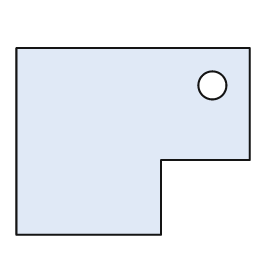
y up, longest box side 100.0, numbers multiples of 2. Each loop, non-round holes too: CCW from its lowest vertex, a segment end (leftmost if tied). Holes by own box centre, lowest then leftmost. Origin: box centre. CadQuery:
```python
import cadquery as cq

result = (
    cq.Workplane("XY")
    .moveTo(-50.0, -40.0)
    .lineTo(12.0, -40.0)
    .lineTo(12.0, -8.0)
    .lineTo(50.0, -8.0)
    .lineTo(50.0, 40.0)
    .lineTo(-50.0, 40.0)
    .close()
    .moveTo(34.0, 24.0)
    .circle(6.0)
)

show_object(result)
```